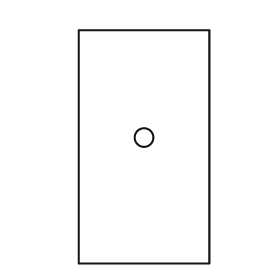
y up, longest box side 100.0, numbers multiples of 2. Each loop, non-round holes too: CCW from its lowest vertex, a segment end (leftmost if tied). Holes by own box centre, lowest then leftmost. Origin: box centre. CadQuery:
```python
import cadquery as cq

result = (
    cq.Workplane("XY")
    .moveTo(-28.0, -50.0)
    .lineTo(28.0, -50.0)
    .lineTo(28.0, 50.0)
    .lineTo(-28.0, 50.0)
    .close()
    .moveTo(0.0, 4.0)
    .circle(4.0)
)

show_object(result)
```